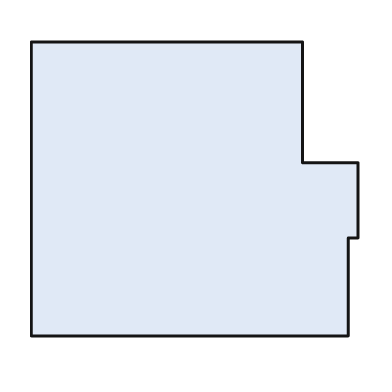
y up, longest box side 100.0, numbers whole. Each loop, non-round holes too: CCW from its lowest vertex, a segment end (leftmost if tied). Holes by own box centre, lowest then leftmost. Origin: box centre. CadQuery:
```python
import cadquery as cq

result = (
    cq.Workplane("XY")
    .moveTo(-50.0, -45.0)
    .lineTo(47.0, -45.0)
    .lineTo(47.0, -15.0)
    .lineTo(50.0, -15.0)
    .lineTo(50.0, 8.0)
    .lineTo(33.0, 8.0)
    .lineTo(33.0, 45.0)
    .lineTo(-50.0, 45.0)
    .close()
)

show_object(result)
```